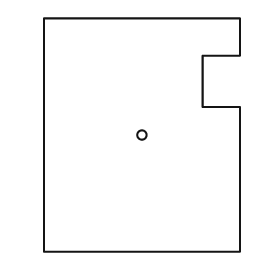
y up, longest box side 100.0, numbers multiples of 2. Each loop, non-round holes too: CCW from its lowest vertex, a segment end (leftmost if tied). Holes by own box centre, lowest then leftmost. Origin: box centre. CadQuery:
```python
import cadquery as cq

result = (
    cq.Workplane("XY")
    .moveTo(-42.0, -50.0)
    .lineTo(42.0, -50.0)
    .lineTo(42.0, 12.0)
    .lineTo(26.0, 12.0)
    .lineTo(26.0, 34.0)
    .lineTo(42.0, 34.0)
    .lineTo(42.0, 50.0)
    .lineTo(-42.0, 50.0)
    .close()
    .moveTo(0.0, 0.0)
    .circle(2.0)
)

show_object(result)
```